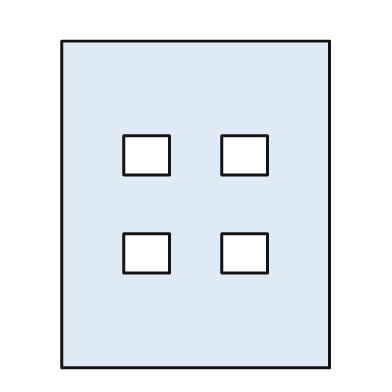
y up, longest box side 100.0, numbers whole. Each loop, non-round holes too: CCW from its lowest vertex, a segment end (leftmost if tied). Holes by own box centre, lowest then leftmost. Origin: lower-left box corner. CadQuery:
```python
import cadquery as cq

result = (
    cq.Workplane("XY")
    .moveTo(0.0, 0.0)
    .lineTo(82.0, 0.0)
    .lineTo(82.0, 100.0)
    .lineTo(0.0, 100.0)
    .close()
    .moveTo(19.0, 29.0)
    .lineTo(33.0, 29.0)
    .lineTo(33.0, 41.0)
    .lineTo(19.0, 41.0)
    .close()
    .moveTo(49.0, 29.0)
    .lineTo(63.0, 29.0)
    .lineTo(63.0, 41.0)
    .lineTo(49.0, 41.0)
    .close()
    .moveTo(19.0, 59.0)
    .lineTo(33.0, 59.0)
    .lineTo(33.0, 71.0)
    .lineTo(19.0, 71.0)
    .close()
    .moveTo(49.0, 59.0)
    .lineTo(63.0, 59.0)
    .lineTo(63.0, 71.0)
    .lineTo(49.0, 71.0)
    .close()
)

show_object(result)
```